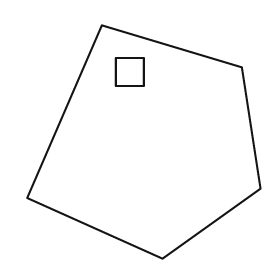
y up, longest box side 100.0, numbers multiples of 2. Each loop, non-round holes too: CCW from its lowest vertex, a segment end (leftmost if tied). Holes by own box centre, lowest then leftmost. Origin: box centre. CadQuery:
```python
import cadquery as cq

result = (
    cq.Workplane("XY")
    .moveTo(8.0, -50.0)
    .lineTo(50.0, -20.0)
    .lineTo(42.0, 32.0)
    .lineTo(-18.0, 50.0)
    .lineTo(-50.0, -24.0)
    .close()
    .moveTo(-12.0, 24.0)
    .lineTo(0.0, 24.0)
    .lineTo(0.0, 36.0)
    .lineTo(-12.0, 36.0)
    .close()
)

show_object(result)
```